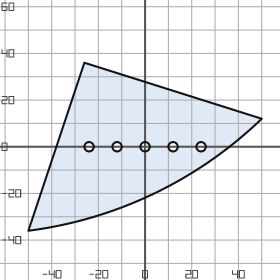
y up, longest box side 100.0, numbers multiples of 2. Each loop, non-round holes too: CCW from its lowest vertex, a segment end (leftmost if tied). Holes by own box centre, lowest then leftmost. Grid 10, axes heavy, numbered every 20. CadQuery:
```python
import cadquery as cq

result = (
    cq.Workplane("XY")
    .moveTo(-50.0, -36.0)
    .threePointArc((4.0, -20.0), (50.0, 12.0))
    .lineTo(-26.0, 36.0)
    .close()
    .moveTo(-24.0, 0.0)
    .circle(2.0)
    .moveTo(-12.0, 0.0)
    .circle(2.0)
    .moveTo(0.0, 0.0)
    .circle(2.0)
    .moveTo(12.0, 0.0)
    .circle(2.0)
    .moveTo(24.0, 0.0)
    .circle(2.0)
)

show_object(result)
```